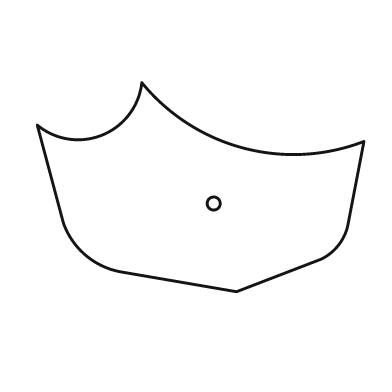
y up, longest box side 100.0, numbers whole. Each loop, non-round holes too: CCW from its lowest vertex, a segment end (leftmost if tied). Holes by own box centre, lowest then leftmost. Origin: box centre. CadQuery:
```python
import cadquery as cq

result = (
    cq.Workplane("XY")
    .moveTo(11.0, -32.0)
    .lineTo(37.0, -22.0)
    .threePointArc((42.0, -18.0), (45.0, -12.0))
    .lineTo(50.0, 14.0)
    .threePointArc((13.0, 12.0), (-18.0, 32.0))
    .threePointArc((-30.0, 16.0), (-50.0, 19.0))
    .lineTo(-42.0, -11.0)
    .threePointArc((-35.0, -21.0), (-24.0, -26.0))
    .close()
    .moveTo(4.0, -5.0)
    .circle(2.0)
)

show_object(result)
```